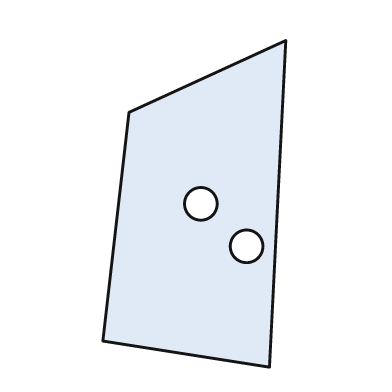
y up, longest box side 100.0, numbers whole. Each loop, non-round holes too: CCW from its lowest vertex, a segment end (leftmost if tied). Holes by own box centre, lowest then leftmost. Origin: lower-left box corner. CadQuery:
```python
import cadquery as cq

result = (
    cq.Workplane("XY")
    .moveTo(51.0, 0.0)
    .lineTo(56.0, 100.0)
    .lineTo(8.0, 78.0)
    .lineTo(0.0, 8.0)
    .close()
    .moveTo(44.0, 37.0)
    .circle(5.0)
    .moveTo(30.0, 50.0)
    .circle(5.0)
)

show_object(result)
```